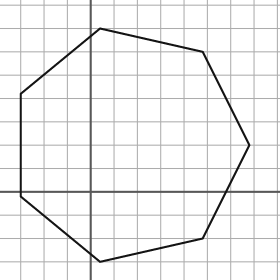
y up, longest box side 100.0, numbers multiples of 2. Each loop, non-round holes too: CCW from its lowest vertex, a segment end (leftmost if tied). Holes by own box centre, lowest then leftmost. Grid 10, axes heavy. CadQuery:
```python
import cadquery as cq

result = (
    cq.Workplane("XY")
    .moveTo(4.0, -30.0)
    .lineTo(48.0, -20.0)
    .lineTo(68.0, 20.0)
    .lineTo(48.0, 60.0)
    .lineTo(4.0, 70.0)
    .lineTo(-30.0, 42.0)
    .lineTo(-30.0, -2.0)
    .close()
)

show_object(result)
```